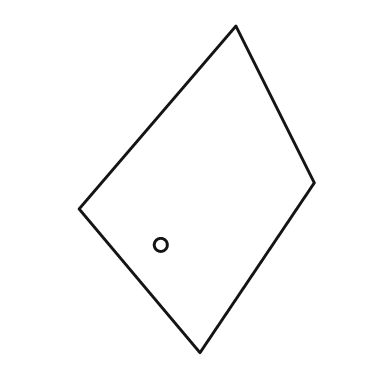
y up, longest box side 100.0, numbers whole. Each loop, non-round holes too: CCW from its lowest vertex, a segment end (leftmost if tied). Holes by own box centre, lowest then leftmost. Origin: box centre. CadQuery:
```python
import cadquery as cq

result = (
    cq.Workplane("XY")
    .moveTo(1.0, -50.0)
    .lineTo(36.0, 2.0)
    .lineTo(12.0, 50.0)
    .lineTo(-36.0, -6.0)
    .close()
    .moveTo(-11.0, -17.0)
    .circle(2.0)
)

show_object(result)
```